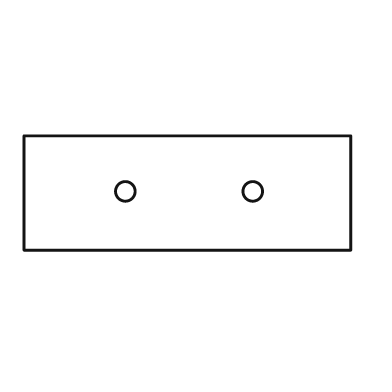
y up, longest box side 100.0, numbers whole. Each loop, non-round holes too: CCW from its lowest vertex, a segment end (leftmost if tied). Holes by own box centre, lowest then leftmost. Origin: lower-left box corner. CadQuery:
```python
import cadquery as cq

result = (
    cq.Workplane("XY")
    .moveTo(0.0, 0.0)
    .lineTo(100.0, 0.0)
    .lineTo(100.0, 35.0)
    .lineTo(0.0, 35.0)
    .close()
    .moveTo(31.0, 18.0)
    .circle(3.0)
    .moveTo(70.0, 18.0)
    .circle(3.0)
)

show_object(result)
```